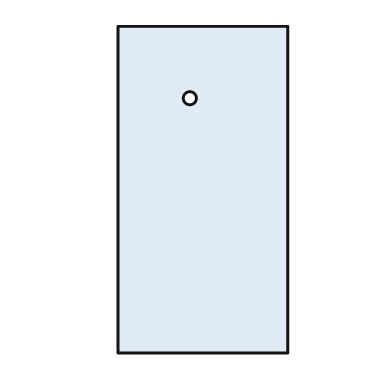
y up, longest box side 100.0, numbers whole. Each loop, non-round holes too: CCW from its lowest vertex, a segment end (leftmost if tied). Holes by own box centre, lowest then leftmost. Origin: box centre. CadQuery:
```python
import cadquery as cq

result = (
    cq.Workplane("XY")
    .moveTo(-26.0, -50.0)
    .lineTo(26.0, -50.0)
    .lineTo(26.0, 50.0)
    .lineTo(-26.0, 50.0)
    .close()
    .moveTo(-4.0, 28.0)
    .circle(2.0)
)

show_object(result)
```